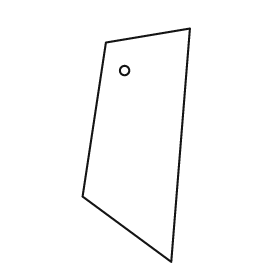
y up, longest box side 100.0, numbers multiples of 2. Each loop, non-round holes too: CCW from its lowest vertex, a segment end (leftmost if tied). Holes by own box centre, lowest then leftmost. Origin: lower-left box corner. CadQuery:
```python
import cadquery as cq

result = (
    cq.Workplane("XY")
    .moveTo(38.0, 0.0)
    .lineTo(46.0, 100.0)
    .lineTo(10.0, 94.0)
    .lineTo(0.0, 28.0)
    .close()
    .moveTo(18.0, 82.0)
    .circle(2.0)
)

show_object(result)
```